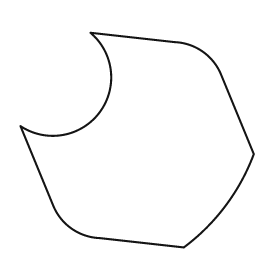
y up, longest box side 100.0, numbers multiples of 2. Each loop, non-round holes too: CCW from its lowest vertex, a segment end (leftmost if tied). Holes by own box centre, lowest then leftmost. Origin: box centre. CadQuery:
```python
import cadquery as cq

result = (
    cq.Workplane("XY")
    .moveTo(20.0, -46.0)
    .threePointArc((38.0, -28.0), (50.0, -6.0))
    .lineTo(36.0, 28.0)
    .threePointArc((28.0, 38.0), (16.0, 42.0))
    .lineTo(-20.0, 46.0)
    .threePointArc((-16.0, 12.0), (-50.0, 6.0))
    .lineTo(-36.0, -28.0)
    .threePointArc((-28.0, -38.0), (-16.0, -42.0))
    .close()
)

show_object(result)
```